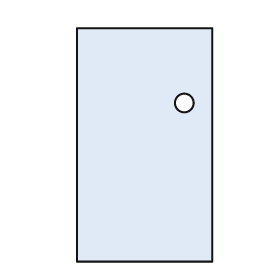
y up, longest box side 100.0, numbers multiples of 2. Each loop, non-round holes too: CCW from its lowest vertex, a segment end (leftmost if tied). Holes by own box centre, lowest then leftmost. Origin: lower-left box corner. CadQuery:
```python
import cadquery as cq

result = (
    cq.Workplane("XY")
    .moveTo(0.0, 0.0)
    .lineTo(58.0, 0.0)
    .lineTo(58.0, 100.0)
    .lineTo(0.0, 100.0)
    .close()
    .moveTo(46.0, 68.0)
    .circle(4.0)
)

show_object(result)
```